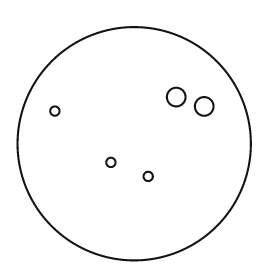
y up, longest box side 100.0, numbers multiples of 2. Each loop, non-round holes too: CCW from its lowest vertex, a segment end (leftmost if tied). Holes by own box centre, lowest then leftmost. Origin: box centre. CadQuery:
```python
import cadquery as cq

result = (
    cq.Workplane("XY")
    .moveTo(0.0, 0.0)
    .circle(50.0)
    .moveTo(6.0, -14.0)
    .circle(2.0)
    .moveTo(-10.0, -8.0)
    .circle(2.0)
    .moveTo(-34.0, 14.0)
    .circle(2.0)
    .moveTo(30.0, 16.0)
    .circle(4.0)
    .moveTo(18.0, 20.0)
    .circle(4.0)
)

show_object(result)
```